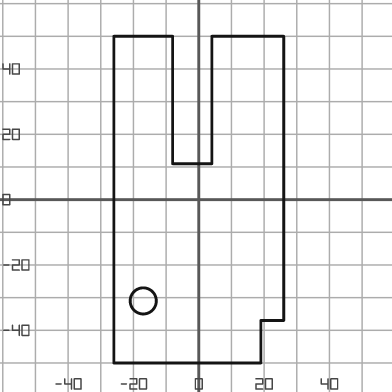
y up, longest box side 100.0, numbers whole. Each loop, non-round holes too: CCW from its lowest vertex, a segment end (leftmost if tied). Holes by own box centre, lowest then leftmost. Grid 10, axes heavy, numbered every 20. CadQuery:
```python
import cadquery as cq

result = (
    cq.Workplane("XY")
    .moveTo(-26.0, -50.0)
    .lineTo(19.0, -50.0)
    .lineTo(19.0, -37.0)
    .lineTo(26.0, -37.0)
    .lineTo(26.0, 50.0)
    .lineTo(4.0, 50.0)
    .lineTo(4.0, 11.0)
    .lineTo(-8.0, 11.0)
    .lineTo(-8.0, 50.0)
    .lineTo(-26.0, 50.0)
    .close()
    .moveTo(-17.0, -31.0)
    .circle(4.0)
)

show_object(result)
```